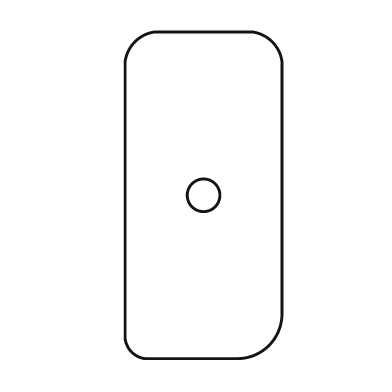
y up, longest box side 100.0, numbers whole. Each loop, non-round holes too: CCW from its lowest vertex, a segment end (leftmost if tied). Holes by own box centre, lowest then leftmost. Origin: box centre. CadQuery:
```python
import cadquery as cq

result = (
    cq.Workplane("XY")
    .moveTo(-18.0, -50.0)
    .lineTo(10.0, -50.0)
    .threePointArc((20.0, -46.0), (24.0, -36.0))
    .lineTo(24.0, 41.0)
    .threePointArc((21.0, 47.0), (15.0, 50.0))
    .lineTo(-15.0, 50.0)
    .threePointArc((-21.0, 47.0), (-24.0, 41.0))
    .lineTo(-24.0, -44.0)
    .threePointArc((-22.0, -48.0), (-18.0, -50.0))
    .close()
    .moveTo(0.0, 0.0)
    .circle(5.0)
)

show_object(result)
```